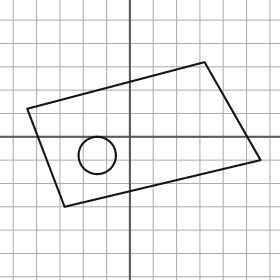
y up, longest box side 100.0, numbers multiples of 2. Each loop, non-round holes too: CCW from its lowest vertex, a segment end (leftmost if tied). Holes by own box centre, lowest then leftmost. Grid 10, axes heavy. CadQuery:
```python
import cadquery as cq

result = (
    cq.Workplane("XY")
    .moveTo(-28.0, -30.0)
    .lineTo(56.0, -10.0)
    .lineTo(32.0, 32.0)
    .lineTo(-44.0, 12.0)
    .close()
    .moveTo(-14.0, -8.0)
    .circle(8.0)
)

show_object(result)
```